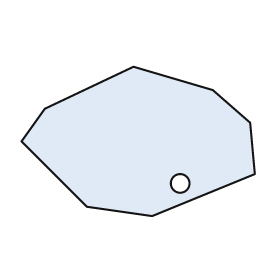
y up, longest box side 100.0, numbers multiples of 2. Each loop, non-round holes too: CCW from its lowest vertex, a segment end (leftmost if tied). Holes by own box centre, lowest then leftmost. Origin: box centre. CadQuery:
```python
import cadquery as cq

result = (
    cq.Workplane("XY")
    .moveTo(6.0, -32.0)
    .lineTo(50.0, -14.0)
    .lineTo(48.0, 8.0)
    .lineTo(32.0, 22.0)
    .lineTo(-2.0, 32.0)
    .lineTo(-40.0, 14.0)
    .lineTo(-50.0, 0.0)
    .lineTo(-22.0, -28.0)
    .close()
    .moveTo(18.0, -18.0)
    .circle(4.0)
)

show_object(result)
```